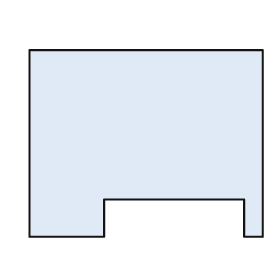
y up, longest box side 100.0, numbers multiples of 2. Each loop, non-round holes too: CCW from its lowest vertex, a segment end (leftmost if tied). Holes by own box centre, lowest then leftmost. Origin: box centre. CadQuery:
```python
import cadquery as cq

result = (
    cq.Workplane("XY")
    .moveTo(-50.0, -40.0)
    .lineTo(-18.0, -40.0)
    .lineTo(-18.0, -24.0)
    .lineTo(42.0, -24.0)
    .lineTo(42.0, -40.0)
    .lineTo(50.0, -40.0)
    .lineTo(50.0, 40.0)
    .lineTo(-50.0, 40.0)
    .close()
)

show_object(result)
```